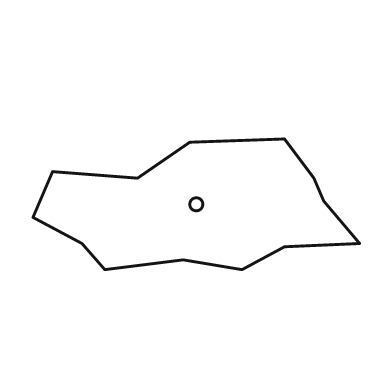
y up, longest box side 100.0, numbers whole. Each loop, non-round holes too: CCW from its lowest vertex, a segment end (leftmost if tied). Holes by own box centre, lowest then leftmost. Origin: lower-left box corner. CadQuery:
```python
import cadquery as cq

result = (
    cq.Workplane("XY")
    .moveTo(22.0, 0.0)
    .lineTo(46.0, 3.0)
    .lineTo(64.0, 0.0)
    .lineTo(77.0, 7.0)
    .lineTo(100.0, 8.0)
    .lineTo(89.0, 21.0)
    .lineTo(86.0, 28.0)
    .lineTo(77.0, 40.0)
    .lineTo(48.0, 39.0)
    .lineTo(32.0, 28.0)
    .lineTo(6.0, 30.0)
    .lineTo(0.0, 16.0)
    .lineTo(15.0, 8.0)
    .close()
    .moveTo(50.0, 20.0)
    .circle(2.0)
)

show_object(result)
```